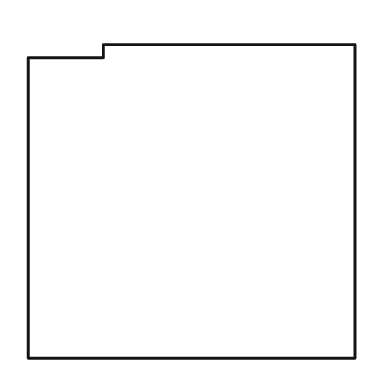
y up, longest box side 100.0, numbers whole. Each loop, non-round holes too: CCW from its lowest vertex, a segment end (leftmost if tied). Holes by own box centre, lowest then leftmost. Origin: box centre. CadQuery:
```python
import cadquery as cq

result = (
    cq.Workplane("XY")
    .moveTo(-50.0, -48.0)
    .lineTo(50.0, -48.0)
    .lineTo(50.0, 48.0)
    .lineTo(-27.0, 48.0)
    .lineTo(-27.0, 44.0)
    .lineTo(-50.0, 44.0)
    .close()
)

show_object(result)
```